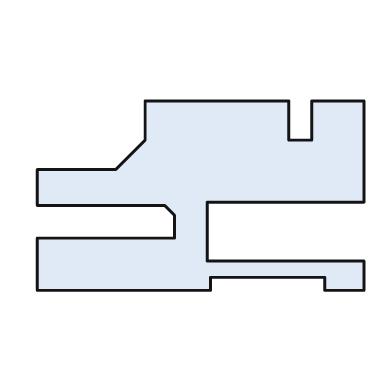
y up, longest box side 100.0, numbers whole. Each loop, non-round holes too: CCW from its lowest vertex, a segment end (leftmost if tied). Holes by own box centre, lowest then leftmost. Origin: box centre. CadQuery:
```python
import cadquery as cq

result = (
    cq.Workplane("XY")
    .moveTo(-50.0, -29.0)
    .lineTo(3.0, -29.0)
    .lineTo(3.0, -25.0)
    .lineTo(38.0, -25.0)
    .lineTo(38.0, -29.0)
    .lineTo(50.0, -29.0)
    .lineTo(50.0, -20.0)
    .lineTo(2.0, -20.0)
    .lineTo(2.0, -2.0)
    .lineTo(50.0, -2.0)
    .lineTo(50.0, 29.0)
    .lineTo(34.0, 29.0)
    .lineTo(34.0, 17.0)
    .lineTo(27.0, 17.0)
    .lineTo(27.0, 29.0)
    .lineTo(-17.0, 29.0)
    .lineTo(-17.0, 17.0)
    .lineTo(-26.0, 8.0)
    .lineTo(-50.0, 8.0)
    .lineTo(-50.0, -3.0)
    .lineTo(-11.0, -3.0)
    .lineTo(-8.0, -6.0)
    .lineTo(-8.0, -13.0)
    .lineTo(-50.0, -13.0)
    .close()
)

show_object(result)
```